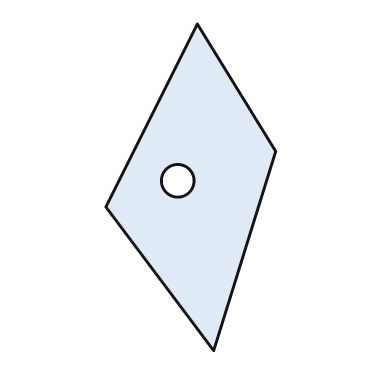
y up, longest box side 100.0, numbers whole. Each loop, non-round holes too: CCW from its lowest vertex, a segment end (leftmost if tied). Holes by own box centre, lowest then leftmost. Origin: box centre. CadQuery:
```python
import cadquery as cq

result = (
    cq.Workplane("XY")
    .moveTo(7.0, -50.0)
    .lineTo(26.0, 11.0)
    .lineTo(2.0, 50.0)
    .lineTo(-26.0, -6.0)
    .close()
    .moveTo(-4.0, 2.0)
    .circle(5.0)
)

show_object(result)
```